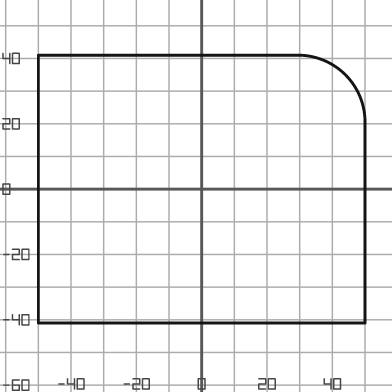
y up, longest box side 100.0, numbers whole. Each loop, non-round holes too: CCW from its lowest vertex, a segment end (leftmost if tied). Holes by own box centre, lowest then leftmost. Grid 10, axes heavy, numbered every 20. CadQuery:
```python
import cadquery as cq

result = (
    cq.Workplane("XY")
    .moveTo(-50.0, -41.0)
    .lineTo(50.0, -41.0)
    .lineTo(50.0, 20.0)
    .threePointArc((44.0, 35.0), (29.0, 41.0))
    .lineTo(-50.0, 41.0)
    .close()
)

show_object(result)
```